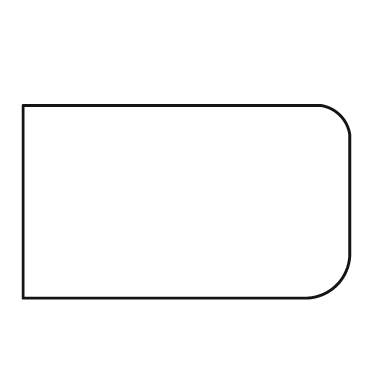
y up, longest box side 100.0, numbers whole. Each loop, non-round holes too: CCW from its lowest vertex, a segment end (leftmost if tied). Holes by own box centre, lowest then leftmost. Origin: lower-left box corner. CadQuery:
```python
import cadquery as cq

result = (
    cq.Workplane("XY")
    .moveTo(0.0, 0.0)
    .lineTo(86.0, 0.0)
    .threePointArc((96.0, 4.0), (100.0, 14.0))
    .lineTo(100.0, 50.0)
    .threePointArc((97.0, 56.0), (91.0, 59.0))
    .lineTo(0.0, 59.0)
    .close()
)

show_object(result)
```